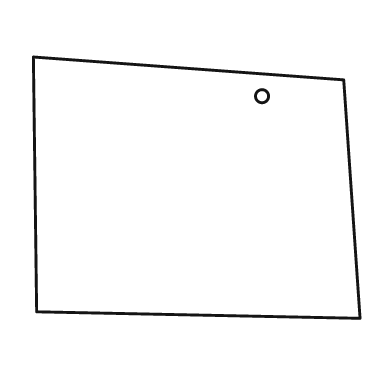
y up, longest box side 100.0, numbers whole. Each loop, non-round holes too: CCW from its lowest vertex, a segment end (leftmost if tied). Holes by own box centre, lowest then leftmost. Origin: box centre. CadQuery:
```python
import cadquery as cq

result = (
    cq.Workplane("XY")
    .moveTo(50.0, -40.0)
    .lineTo(45.0, 33.0)
    .lineTo(-50.0, 40.0)
    .lineTo(-49.0, -38.0)
    .close()
    .moveTo(20.0, 28.0)
    .circle(2.0)
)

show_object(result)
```